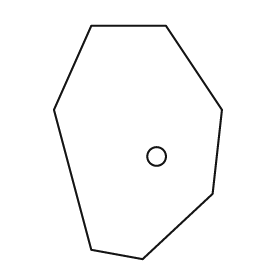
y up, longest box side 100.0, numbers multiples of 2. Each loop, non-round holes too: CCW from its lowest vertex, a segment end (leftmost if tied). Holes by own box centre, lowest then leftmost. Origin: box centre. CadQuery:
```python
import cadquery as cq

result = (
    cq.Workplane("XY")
    .moveTo(2.0, -50.0)
    .lineTo(32.0, -22.0)
    .lineTo(36.0, 14.0)
    .lineTo(12.0, 50.0)
    .lineTo(-20.0, 50.0)
    .lineTo(-36.0, 14.0)
    .lineTo(-20.0, -46.0)
    .close()
    .moveTo(8.0, -6.0)
    .circle(4.0)
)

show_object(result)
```